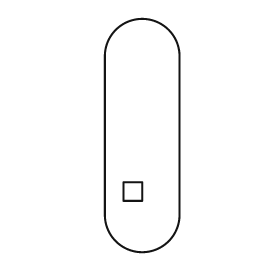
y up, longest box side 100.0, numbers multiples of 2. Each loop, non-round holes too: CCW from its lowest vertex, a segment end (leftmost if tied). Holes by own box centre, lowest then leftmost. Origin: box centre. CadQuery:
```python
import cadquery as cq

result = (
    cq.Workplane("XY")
    .moveTo(-16.0, -34.0)
    .threePointArc((0.0, -50.0), (16.0, -34.0))
    .lineTo(16.0, 34.0)
    .threePointArc((0.0, 50.0), (-16.0, 34.0))
    .close()
    .moveTo(-8.0, -28.0)
    .lineTo(0.0, -28.0)
    .lineTo(0.0, -20.0)
    .lineTo(-8.0, -20.0)
    .close()
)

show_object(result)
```